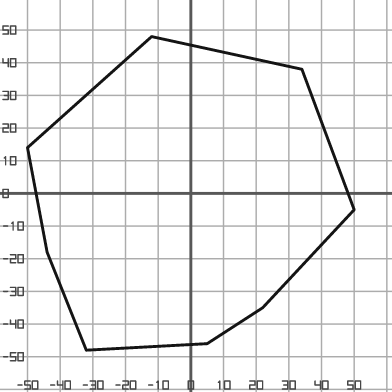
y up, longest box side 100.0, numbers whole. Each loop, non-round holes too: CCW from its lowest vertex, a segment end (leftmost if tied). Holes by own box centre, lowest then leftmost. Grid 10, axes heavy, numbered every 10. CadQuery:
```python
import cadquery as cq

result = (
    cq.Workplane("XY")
    .moveTo(-32.0, -48.0)
    .lineTo(5.0, -46.0)
    .lineTo(22.0, -35.0)
    .lineTo(50.0, -5.0)
    .lineTo(34.0, 38.0)
    .lineTo(-12.0, 48.0)
    .lineTo(-50.0, 14.0)
    .lineTo(-44.0, -18.0)
    .close()
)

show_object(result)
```